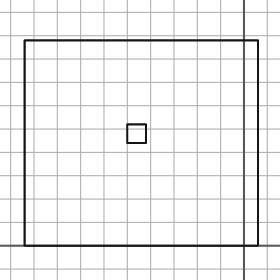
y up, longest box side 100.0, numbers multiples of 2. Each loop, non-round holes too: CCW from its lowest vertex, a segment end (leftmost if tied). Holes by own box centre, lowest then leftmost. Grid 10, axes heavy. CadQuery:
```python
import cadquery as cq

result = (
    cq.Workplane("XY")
    .moveTo(-94.0, 0.0)
    .lineTo(6.0, 0.0)
    .lineTo(6.0, 88.0)
    .lineTo(-94.0, 88.0)
    .close()
    .moveTo(-50.0, 44.0)
    .lineTo(-42.0, 44.0)
    .lineTo(-42.0, 52.0)
    .lineTo(-50.0, 52.0)
    .close()
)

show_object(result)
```